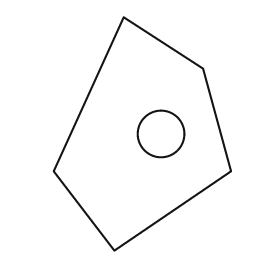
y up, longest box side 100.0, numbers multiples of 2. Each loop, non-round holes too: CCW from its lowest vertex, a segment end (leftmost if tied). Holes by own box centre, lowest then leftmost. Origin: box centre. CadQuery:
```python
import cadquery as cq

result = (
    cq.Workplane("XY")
    .moveTo(-12.0, -50.0)
    .lineTo(38.0, -16.0)
    .lineTo(26.0, 28.0)
    .lineTo(-8.0, 50.0)
    .lineTo(-38.0, -16.0)
    .close()
    .moveTo(8.0, 0.0)
    .circle(10.0)
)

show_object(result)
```